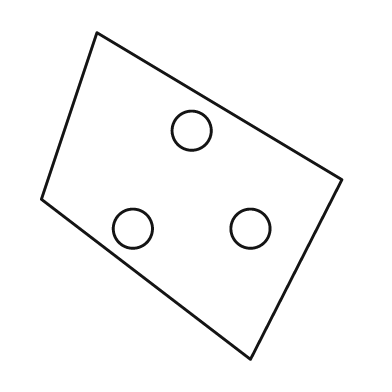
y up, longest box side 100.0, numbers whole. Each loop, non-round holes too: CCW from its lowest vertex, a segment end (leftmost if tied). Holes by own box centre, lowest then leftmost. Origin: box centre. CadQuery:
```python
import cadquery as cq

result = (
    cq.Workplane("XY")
    .moveTo(18.0, -50.0)
    .lineTo(46.0, 5.0)
    .lineTo(-29.0, 50.0)
    .lineTo(-46.0, -1.0)
    .close()
    .moveTo(-18.0, -10.0)
    .circle(6.0)
    .moveTo(18.0, -10.0)
    .circle(6.0)
    .moveTo(0.0, 20.0)
    .circle(6.0)
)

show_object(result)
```